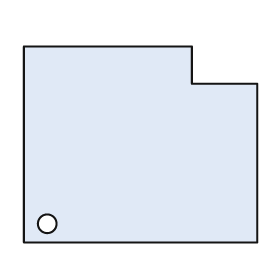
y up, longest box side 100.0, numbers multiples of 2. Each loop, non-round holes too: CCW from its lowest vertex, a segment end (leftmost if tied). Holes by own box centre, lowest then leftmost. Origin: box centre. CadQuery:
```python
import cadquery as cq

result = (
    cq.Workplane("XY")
    .moveTo(-50.0, -42.0)
    .lineTo(50.0, -42.0)
    .lineTo(50.0, 26.0)
    .lineTo(22.0, 26.0)
    .lineTo(22.0, 42.0)
    .lineTo(-50.0, 42.0)
    .close()
    .moveTo(-40.0, -34.0)
    .circle(4.0)
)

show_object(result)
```